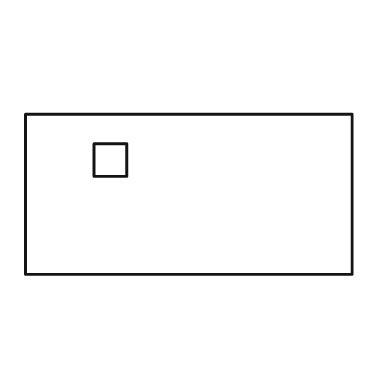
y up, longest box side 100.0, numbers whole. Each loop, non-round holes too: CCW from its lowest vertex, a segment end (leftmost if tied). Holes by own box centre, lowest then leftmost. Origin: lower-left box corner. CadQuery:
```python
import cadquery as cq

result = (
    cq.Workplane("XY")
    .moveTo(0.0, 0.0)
    .lineTo(100.0, 0.0)
    .lineTo(100.0, 49.0)
    .lineTo(0.0, 49.0)
    .close()
    .moveTo(21.0, 30.0)
    .lineTo(31.0, 30.0)
    .lineTo(31.0, 40.0)
    .lineTo(21.0, 40.0)
    .close()
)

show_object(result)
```